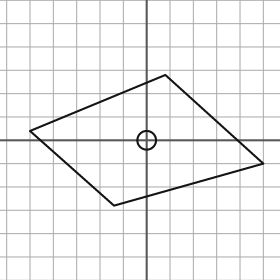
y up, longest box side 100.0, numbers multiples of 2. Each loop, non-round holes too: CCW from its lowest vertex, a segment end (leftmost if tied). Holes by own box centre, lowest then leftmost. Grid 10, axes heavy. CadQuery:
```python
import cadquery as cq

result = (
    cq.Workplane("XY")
    .moveTo(-14.0, -28.0)
    .lineTo(50.0, -10.0)
    .lineTo(8.0, 28.0)
    .lineTo(-50.0, 4.0)
    .close()
    .moveTo(0.0, 0.0)
    .circle(4.0)
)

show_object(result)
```